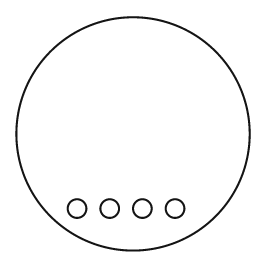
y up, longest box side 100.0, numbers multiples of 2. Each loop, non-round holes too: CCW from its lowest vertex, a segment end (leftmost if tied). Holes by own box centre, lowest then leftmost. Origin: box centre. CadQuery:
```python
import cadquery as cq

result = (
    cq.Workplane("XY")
    .moveTo(0.0, 0.0)
    .circle(50.0)
    .moveTo(-24.0, -32.0)
    .circle(4.0)
    .moveTo(-10.0, -32.0)
    .circle(4.0)
    .moveTo(4.0, -32.0)
    .circle(4.0)
    .moveTo(18.0, -32.0)
    .circle(4.0)
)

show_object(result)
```